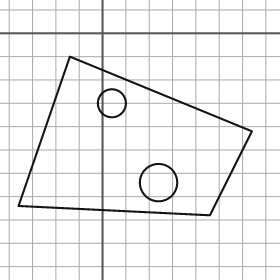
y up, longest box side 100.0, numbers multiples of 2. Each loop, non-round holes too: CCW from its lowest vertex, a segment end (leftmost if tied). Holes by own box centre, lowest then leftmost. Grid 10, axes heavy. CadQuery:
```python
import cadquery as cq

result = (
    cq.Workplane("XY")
    .moveTo(46.0, -78.0)
    .lineTo(64.0, -42.0)
    .lineTo(-14.0, -10.0)
    .lineTo(-36.0, -74.0)
    .close()
    .moveTo(24.0, -64.0)
    .circle(8.0)
    .moveTo(4.0, -30.0)
    .circle(6.0)
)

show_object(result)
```